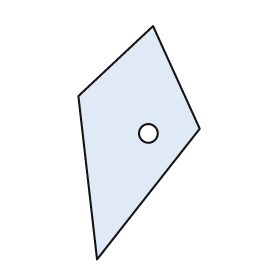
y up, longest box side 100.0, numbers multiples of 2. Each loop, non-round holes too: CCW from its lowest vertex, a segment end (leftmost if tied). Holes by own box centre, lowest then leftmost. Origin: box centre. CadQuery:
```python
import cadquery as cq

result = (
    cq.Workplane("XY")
    .moveTo(-18.0, -50.0)
    .lineTo(26.0, 6.0)
    .lineTo(6.0, 50.0)
    .lineTo(-26.0, 20.0)
    .close()
    .moveTo(4.0, 4.0)
    .circle(4.0)
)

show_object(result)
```